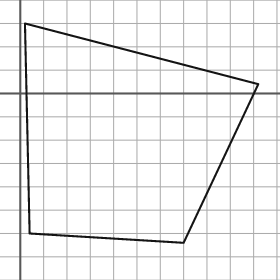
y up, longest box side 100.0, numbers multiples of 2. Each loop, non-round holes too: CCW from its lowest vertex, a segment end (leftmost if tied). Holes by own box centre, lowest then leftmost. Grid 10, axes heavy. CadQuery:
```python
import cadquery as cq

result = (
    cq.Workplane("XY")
    .moveTo(70.0, -64.0)
    .lineTo(102.0, 4.0)
    .lineTo(2.0, 30.0)
    .lineTo(4.0, -60.0)
    .close()
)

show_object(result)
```